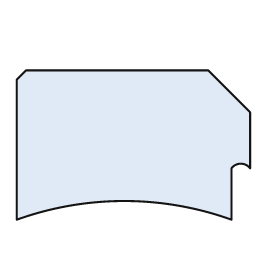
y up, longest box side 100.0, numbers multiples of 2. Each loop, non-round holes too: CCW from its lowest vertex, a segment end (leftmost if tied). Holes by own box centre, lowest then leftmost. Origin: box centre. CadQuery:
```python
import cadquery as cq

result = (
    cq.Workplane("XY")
    .moveTo(-50.0, -32.0)
    .threePointArc((-4.0, -24.0), (42.0, -32.0))
    .lineTo(42.0, -10.0)
    .threePointArc((46.0, -8.0), (50.0, -10.0))
    .lineTo(50.0, 14.0)
    .lineTo(32.0, 32.0)
    .lineTo(-46.0, 32.0)
    .lineTo(-50.0, 28.0)
    .close()
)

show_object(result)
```